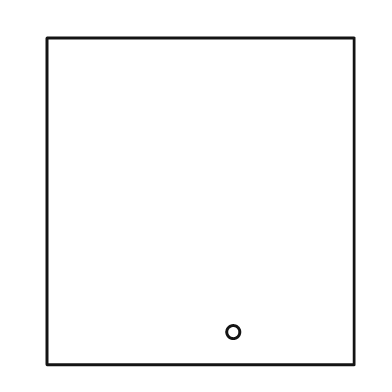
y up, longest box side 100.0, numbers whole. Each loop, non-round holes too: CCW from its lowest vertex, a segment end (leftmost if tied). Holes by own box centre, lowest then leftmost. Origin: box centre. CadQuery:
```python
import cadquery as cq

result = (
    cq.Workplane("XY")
    .moveTo(-47.0, -50.0)
    .lineTo(47.0, -50.0)
    .lineTo(47.0, 50.0)
    .lineTo(-47.0, 50.0)
    .close()
    .moveTo(10.0, -40.0)
    .circle(2.0)
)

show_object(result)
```